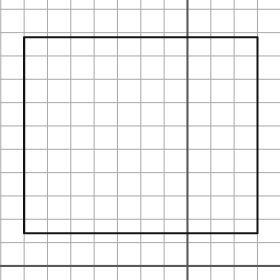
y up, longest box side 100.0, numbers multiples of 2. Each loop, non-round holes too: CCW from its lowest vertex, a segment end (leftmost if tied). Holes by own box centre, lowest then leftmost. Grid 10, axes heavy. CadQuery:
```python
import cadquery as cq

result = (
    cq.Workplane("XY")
    .moveTo(-70.0, 14.0)
    .lineTo(30.0, 14.0)
    .lineTo(30.0, 98.0)
    .lineTo(-70.0, 98.0)
    .close()
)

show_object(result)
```